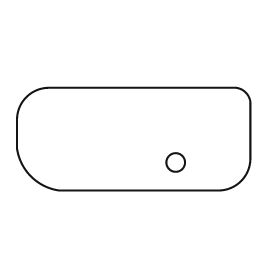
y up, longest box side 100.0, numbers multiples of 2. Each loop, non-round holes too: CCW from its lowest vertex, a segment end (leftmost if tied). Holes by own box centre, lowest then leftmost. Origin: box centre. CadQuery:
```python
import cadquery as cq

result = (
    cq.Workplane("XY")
    .moveTo(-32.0, -22.0)
    .lineTo(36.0, -22.0)
    .threePointArc((46.0, -18.0), (50.0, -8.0))
    .lineTo(50.0, 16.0)
    .threePointArc((48.0, 20.0), (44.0, 22.0))
    .lineTo(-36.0, 22.0)
    .threePointArc((-46.0, 18.0), (-50.0, 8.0))
    .lineTo(-50.0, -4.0)
    .threePointArc((-44.0, -16.0), (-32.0, -22.0))
    .close()
    .moveTo(18.0, -10.0)
    .circle(4.0)
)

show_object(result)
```